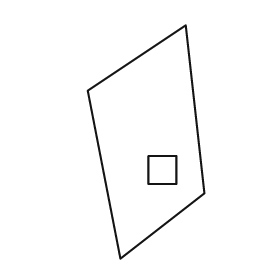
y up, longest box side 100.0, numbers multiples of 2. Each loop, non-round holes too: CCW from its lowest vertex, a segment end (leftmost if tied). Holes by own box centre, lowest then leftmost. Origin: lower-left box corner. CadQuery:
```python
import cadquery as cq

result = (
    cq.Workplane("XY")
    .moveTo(14.0, 0.0)
    .lineTo(50.0, 28.0)
    .lineTo(42.0, 100.0)
    .lineTo(0.0, 72.0)
    .close()
    .moveTo(26.0, 32.0)
    .lineTo(38.0, 32.0)
    .lineTo(38.0, 44.0)
    .lineTo(26.0, 44.0)
    .close()
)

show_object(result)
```